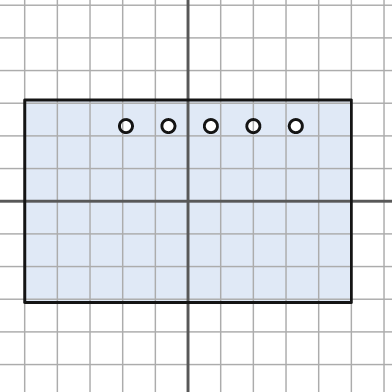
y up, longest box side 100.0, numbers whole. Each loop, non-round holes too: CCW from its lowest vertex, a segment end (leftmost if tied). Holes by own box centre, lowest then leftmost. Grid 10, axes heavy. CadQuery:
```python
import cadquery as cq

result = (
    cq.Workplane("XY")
    .moveTo(-50.0, -31.0)
    .lineTo(50.0, -31.0)
    .lineTo(50.0, 31.0)
    .lineTo(-50.0, 31.0)
    .close()
    .moveTo(-19.0, 23.0)
    .circle(2.0)
    .moveTo(-6.0, 23.0)
    .circle(2.0)
    .moveTo(7.0, 23.0)
    .circle(2.0)
    .moveTo(20.0, 23.0)
    .circle(2.0)
    .moveTo(33.0, 23.0)
    .circle(2.0)
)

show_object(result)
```